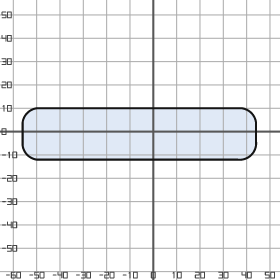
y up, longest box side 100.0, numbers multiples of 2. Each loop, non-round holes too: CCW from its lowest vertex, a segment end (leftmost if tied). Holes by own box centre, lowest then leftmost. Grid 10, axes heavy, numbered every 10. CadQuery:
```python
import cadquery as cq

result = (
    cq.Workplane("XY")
    .moveTo(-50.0, -12.0)
    .lineTo(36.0, -12.0)
    .threePointArc((42.0, -10.0), (44.0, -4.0))
    .lineTo(44.0, 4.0)
    .threePointArc((42.0, 8.0), (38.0, 10.0))
    .lineTo(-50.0, 10.0)
    .threePointArc((-54.0, 8.0), (-56.0, 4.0))
    .lineTo(-56.0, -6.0)
    .threePointArc((-54.0, -10.0), (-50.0, -12.0))
    .close()
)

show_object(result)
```